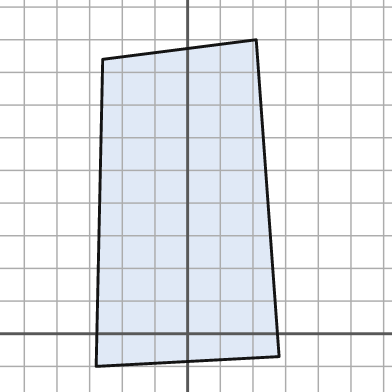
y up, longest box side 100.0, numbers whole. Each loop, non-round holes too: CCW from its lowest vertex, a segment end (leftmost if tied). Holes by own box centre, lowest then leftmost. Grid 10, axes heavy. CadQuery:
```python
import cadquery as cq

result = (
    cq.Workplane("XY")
    .moveTo(-28.0, -10.0)
    .lineTo(28.0, -7.0)
    .lineTo(21.0, 90.0)
    .lineTo(-26.0, 84.0)
    .close()
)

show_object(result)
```